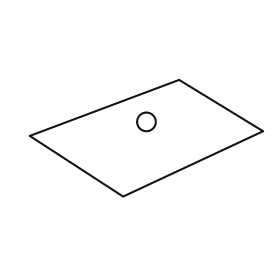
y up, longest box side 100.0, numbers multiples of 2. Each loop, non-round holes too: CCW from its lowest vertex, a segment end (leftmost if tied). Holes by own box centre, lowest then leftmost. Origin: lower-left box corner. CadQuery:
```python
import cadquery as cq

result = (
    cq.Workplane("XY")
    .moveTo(40.0, 0.0)
    .lineTo(100.0, 28.0)
    .lineTo(64.0, 50.0)
    .lineTo(0.0, 26.0)
    .close()
    .moveTo(50.0, 32.0)
    .circle(4.0)
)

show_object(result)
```